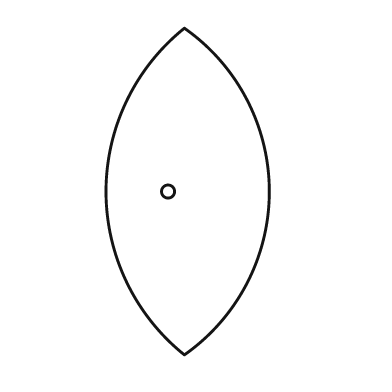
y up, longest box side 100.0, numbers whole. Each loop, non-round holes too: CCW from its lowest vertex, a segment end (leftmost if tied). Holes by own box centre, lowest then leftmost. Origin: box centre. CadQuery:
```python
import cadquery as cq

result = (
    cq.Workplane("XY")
    .moveTo(-1.0, -50.0)
    .threePointArc((25.0, 0.0), (-1.0, 50.0))
    .threePointArc((-25.0, 0.0), (-1.0, -50.0))
    .close()
    .moveTo(-6.0, 0.0)
    .circle(2.0)
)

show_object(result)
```